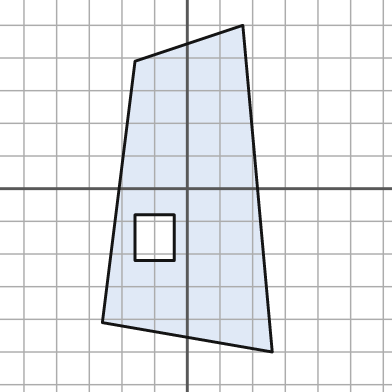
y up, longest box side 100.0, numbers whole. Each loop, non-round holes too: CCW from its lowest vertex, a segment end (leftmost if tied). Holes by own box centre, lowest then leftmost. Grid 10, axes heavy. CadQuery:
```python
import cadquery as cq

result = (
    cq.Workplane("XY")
    .moveTo(26.0, -50.0)
    .lineTo(17.0, 50.0)
    .lineTo(-16.0, 39.0)
    .lineTo(-26.0, -41.0)
    .close()
    .moveTo(-16.0, -22.0)
    .lineTo(-4.0, -22.0)
    .lineTo(-4.0, -8.0)
    .lineTo(-16.0, -8.0)
    .close()
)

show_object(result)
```